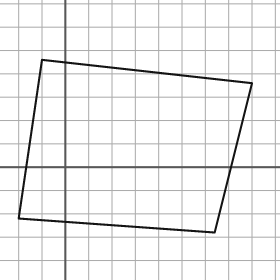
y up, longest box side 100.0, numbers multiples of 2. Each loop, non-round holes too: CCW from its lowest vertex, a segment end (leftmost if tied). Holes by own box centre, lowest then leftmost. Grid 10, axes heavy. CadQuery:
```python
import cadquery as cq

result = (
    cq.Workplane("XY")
    .moveTo(64.0, -28.0)
    .lineTo(80.0, 36.0)
    .lineTo(-10.0, 46.0)
    .lineTo(-20.0, -22.0)
    .close()
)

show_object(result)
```